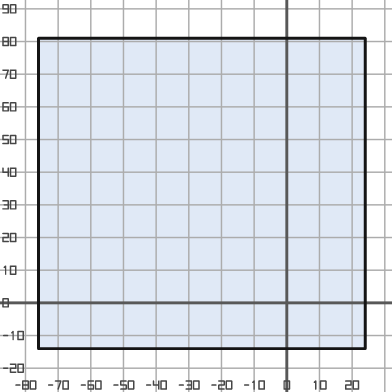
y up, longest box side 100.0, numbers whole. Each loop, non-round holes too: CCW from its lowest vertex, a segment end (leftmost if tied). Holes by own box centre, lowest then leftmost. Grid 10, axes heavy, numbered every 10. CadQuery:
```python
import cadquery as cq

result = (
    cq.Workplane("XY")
    .moveTo(-76.0, -14.0)
    .lineTo(24.0, -14.0)
    .lineTo(24.0, 81.0)
    .lineTo(-76.0, 81.0)
    .close()
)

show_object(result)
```